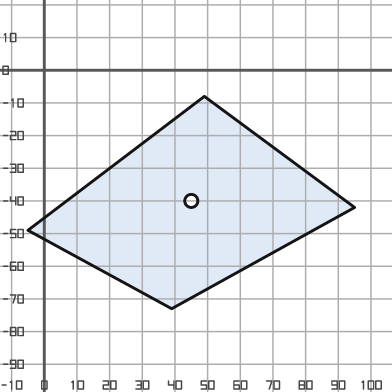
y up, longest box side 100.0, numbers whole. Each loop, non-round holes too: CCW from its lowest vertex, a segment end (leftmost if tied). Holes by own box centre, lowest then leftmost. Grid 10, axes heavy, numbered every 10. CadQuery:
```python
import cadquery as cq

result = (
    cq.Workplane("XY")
    .moveTo(39.0, -73.0)
    .lineTo(95.0, -42.0)
    .lineTo(49.0, -8.0)
    .lineTo(-5.0, -49.0)
    .close()
    .moveTo(45.0, -40.0)
    .circle(2.0)
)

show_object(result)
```